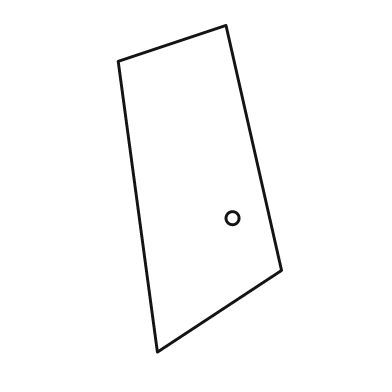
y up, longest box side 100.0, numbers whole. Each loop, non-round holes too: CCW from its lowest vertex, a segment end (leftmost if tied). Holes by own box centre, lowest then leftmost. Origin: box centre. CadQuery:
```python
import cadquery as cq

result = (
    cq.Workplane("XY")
    .moveTo(-13.0, -50.0)
    .lineTo(25.0, -25.0)
    .lineTo(8.0, 50.0)
    .lineTo(-25.0, 39.0)
    .close()
    .moveTo(10.0, -9.0)
    .circle(2.0)
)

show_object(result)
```